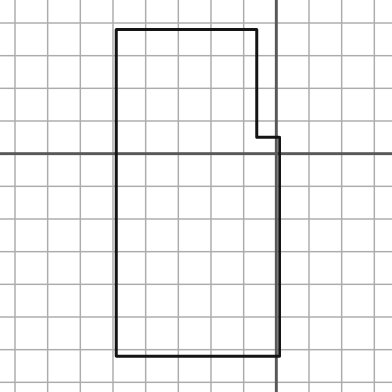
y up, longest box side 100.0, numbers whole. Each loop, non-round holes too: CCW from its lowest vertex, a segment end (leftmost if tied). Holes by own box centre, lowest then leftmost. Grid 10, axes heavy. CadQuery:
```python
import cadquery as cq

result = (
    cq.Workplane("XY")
    .moveTo(-49.0, -62.0)
    .lineTo(1.0, -62.0)
    .lineTo(1.0, 5.0)
    .lineTo(-6.0, 5.0)
    .lineTo(-6.0, 38.0)
    .lineTo(-49.0, 38.0)
    .close()
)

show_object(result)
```